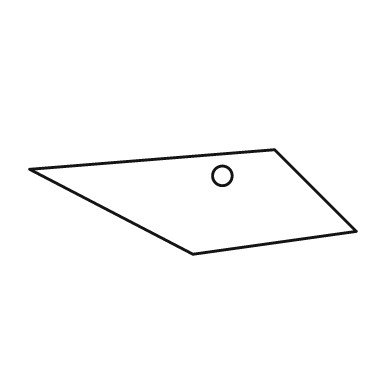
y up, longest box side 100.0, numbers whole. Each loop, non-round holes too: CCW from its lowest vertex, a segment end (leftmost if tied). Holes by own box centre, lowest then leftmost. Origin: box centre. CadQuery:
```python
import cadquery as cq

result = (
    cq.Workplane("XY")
    .moveTo(0.0, -16.0)
    .lineTo(50.0, -9.0)
    .lineTo(25.0, 16.0)
    .lineTo(-50.0, 10.0)
    .close()
    .moveTo(9.0, 8.0)
    .circle(3.0)
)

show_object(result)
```